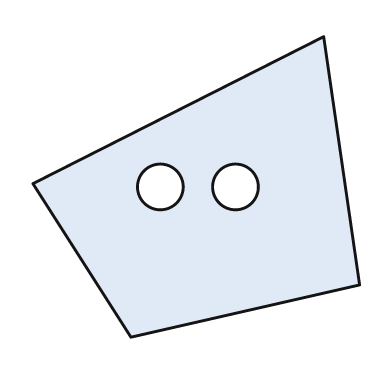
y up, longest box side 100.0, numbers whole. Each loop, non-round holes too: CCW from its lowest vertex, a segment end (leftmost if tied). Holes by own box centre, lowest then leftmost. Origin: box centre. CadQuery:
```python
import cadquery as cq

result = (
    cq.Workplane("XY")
    .moveTo(-20.0, -46.0)
    .lineTo(50.0, -30.0)
    .lineTo(39.0, 46.0)
    .lineTo(-50.0, 1.0)
    .close()
    .moveTo(-11.0, 0.0)
    .circle(7.0)
    .moveTo(12.0, 0.0)
    .circle(7.0)
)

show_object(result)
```